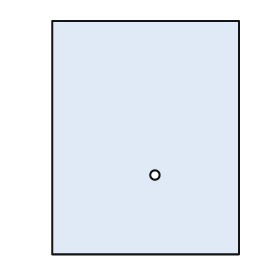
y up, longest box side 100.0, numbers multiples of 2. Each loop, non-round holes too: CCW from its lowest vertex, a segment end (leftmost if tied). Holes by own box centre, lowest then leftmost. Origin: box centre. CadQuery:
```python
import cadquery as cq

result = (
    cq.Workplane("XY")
    .moveTo(-40.0, -50.0)
    .lineTo(40.0, -50.0)
    .lineTo(40.0, 50.0)
    .lineTo(-40.0, 50.0)
    .close()
    .moveTo(4.0, -16.0)
    .circle(2.0)
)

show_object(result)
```